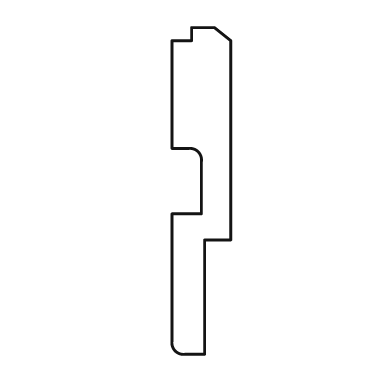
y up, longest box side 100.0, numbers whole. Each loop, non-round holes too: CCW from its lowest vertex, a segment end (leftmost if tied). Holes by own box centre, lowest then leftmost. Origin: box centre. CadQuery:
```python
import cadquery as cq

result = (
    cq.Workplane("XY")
    .moveTo(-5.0, -50.0)
    .lineTo(1.0, -50.0)
    .lineTo(1.0, -15.0)
    .lineTo(9.0, -15.0)
    .lineTo(9.0, 46.0)
    .lineTo(4.0, 50.0)
    .lineTo(-3.0, 50.0)
    .lineTo(-3.0, 46.0)
    .lineTo(-9.0, 46.0)
    .lineTo(-9.0, 13.0)
    .lineTo(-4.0, 13.0)
    .threePointArc((-1.0, 12.0), (0.0, 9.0))
    .lineTo(0.0, -7.0)
    .lineTo(-9.0, -7.0)
    .lineTo(-9.0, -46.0)
    .threePointArc((-8.0, -49.0), (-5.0, -50.0))
    .close()
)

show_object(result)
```